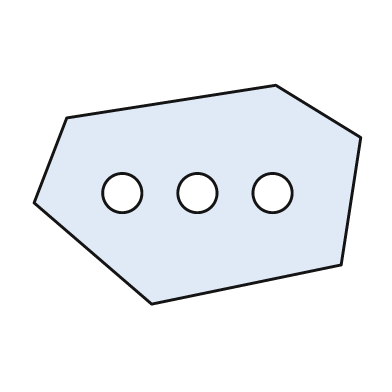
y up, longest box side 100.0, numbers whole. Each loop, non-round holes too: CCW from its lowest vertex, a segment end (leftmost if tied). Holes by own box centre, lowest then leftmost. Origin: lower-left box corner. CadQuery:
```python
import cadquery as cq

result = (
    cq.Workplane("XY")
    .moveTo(36.0, 0.0)
    .lineTo(94.0, 12.0)
    .lineTo(100.0, 51.0)
    .lineTo(74.0, 67.0)
    .lineTo(10.0, 57.0)
    .lineTo(0.0, 31.0)
    .close()
    .moveTo(27.0, 34.0)
    .circle(6.0)
    .moveTo(50.0, 34.0)
    .circle(6.0)
    .moveTo(73.0, 34.0)
    .circle(6.0)
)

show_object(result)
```